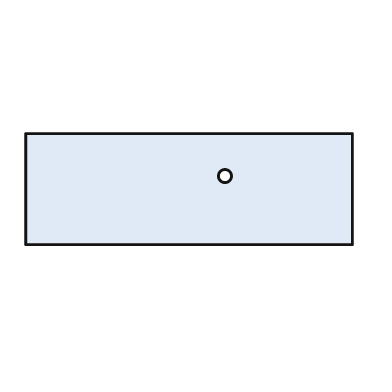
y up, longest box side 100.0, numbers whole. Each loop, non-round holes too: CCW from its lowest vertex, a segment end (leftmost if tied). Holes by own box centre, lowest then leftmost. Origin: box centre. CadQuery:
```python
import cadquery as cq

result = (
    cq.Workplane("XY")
    .moveTo(-50.0, -17.0)
    .lineTo(50.0, -17.0)
    .lineTo(50.0, 17.0)
    .lineTo(-50.0, 17.0)
    .close()
    .moveTo(11.0, 4.0)
    .circle(2.0)
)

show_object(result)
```